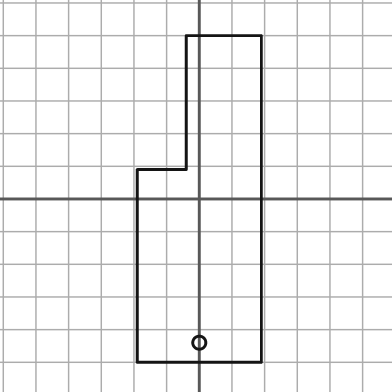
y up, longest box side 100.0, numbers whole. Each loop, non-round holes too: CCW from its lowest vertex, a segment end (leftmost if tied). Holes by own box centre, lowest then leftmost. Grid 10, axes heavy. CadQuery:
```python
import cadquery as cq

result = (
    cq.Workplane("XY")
    .moveTo(-19.0, -50.0)
    .lineTo(19.0, -50.0)
    .lineTo(19.0, 50.0)
    .lineTo(-4.0, 50.0)
    .lineTo(-4.0, 9.0)
    .lineTo(-19.0, 9.0)
    .close()
    .moveTo(0.0, -44.0)
    .circle(2.0)
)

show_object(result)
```